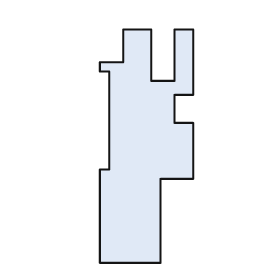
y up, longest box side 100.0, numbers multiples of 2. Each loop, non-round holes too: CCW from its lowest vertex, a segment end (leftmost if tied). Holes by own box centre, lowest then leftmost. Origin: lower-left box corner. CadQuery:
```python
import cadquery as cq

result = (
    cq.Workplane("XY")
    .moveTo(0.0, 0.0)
    .lineTo(26.0, 0.0)
    .lineTo(26.0, 36.0)
    .lineTo(40.0, 36.0)
    .lineTo(40.0, 60.0)
    .lineTo(32.0, 60.0)
    .lineTo(32.0, 72.0)
    .lineTo(40.0, 72.0)
    .lineTo(40.0, 100.0)
    .lineTo(32.0, 100.0)
    .lineTo(32.0, 78.0)
    .lineTo(22.0, 78.0)
    .lineTo(22.0, 100.0)
    .lineTo(10.0, 100.0)
    .lineTo(10.0, 86.0)
    .lineTo(0.0, 86.0)
    .lineTo(0.0, 82.0)
    .lineTo(4.0, 82.0)
    .lineTo(4.0, 40.0)
    .lineTo(0.0, 40.0)
    .close()
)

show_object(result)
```